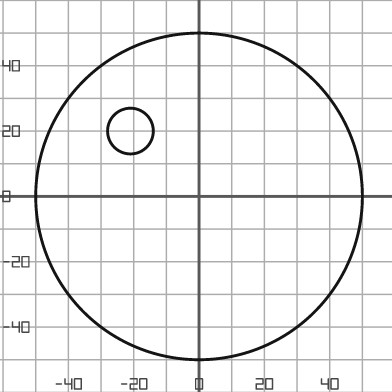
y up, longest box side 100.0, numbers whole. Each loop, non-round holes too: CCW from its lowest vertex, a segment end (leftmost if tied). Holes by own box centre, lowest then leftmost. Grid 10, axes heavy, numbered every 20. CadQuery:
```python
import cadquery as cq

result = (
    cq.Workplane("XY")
    .moveTo(0.0, 0.0)
    .circle(50.0)
    .moveTo(-21.0, 20.0)
    .circle(7.0)
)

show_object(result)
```